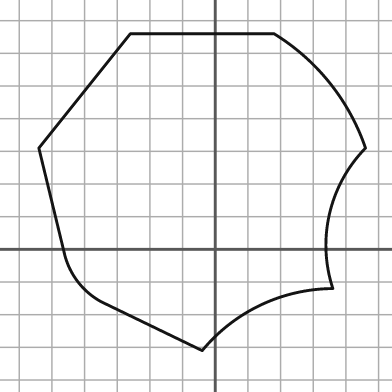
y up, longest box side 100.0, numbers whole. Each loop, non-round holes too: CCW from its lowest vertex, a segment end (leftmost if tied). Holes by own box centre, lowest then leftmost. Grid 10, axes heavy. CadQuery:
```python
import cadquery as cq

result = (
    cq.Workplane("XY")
    .moveTo(-4.0, -31.0)
    .threePointArc((14.0, -17.0), (36.0, -12.0))
    .threePointArc((35.0, 11.0), (46.0, 31.0))
    .threePointArc((35.0, 51.0), (18.0, 66.0))
    .lineTo(-26.0, 66.0)
    .lineTo(-54.0, 31.0)
    .lineTo(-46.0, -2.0)
    .threePointArc((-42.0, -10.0), (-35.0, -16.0))
    .close()
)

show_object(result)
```